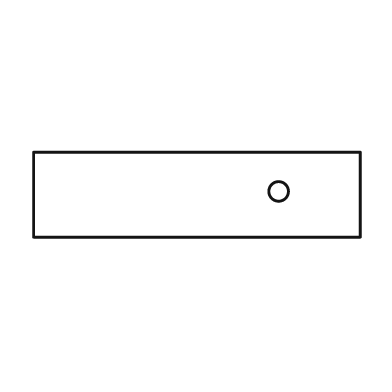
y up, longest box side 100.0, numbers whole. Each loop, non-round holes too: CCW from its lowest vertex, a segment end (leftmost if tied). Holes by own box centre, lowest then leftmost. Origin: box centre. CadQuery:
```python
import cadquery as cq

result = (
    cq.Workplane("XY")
    .moveTo(-50.0, -13.0)
    .lineTo(50.0, -13.0)
    .lineTo(50.0, 13.0)
    .lineTo(-50.0, 13.0)
    .close()
    .moveTo(25.0, 1.0)
    .circle(3.0)
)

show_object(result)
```